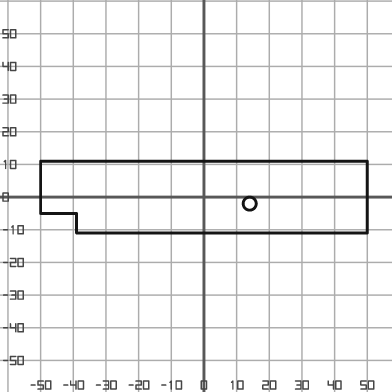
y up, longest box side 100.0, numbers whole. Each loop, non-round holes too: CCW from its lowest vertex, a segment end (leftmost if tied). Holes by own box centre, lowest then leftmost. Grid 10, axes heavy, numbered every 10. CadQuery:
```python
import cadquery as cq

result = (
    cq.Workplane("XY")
    .moveTo(-39.0, -11.0)
    .lineTo(50.0, -11.0)
    .lineTo(50.0, 11.0)
    .lineTo(-50.0, 11.0)
    .lineTo(-50.0, -5.0)
    .lineTo(-39.0, -5.0)
    .close()
    .moveTo(14.0, -2.0)
    .circle(2.0)
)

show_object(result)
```